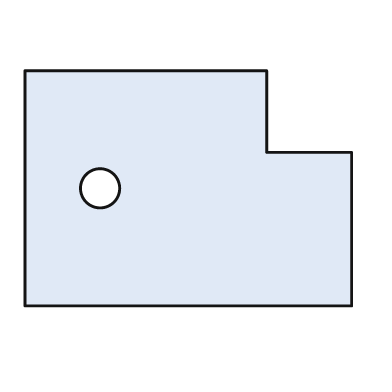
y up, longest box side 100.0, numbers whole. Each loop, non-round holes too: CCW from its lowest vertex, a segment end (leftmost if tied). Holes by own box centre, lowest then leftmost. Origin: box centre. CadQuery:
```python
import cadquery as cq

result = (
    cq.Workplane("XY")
    .moveTo(-50.0, -36.0)
    .lineTo(50.0, -36.0)
    .lineTo(50.0, 11.0)
    .lineTo(24.0, 11.0)
    .lineTo(24.0, 36.0)
    .lineTo(-50.0, 36.0)
    .close()
    .moveTo(-27.0, 0.0)
    .circle(6.0)
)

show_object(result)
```